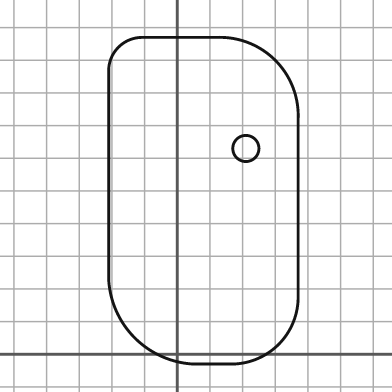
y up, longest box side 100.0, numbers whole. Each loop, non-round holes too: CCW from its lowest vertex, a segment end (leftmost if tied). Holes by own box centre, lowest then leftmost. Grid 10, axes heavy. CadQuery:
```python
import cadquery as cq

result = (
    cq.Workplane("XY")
    .moveTo(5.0, -3.0)
    .lineTo(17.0, -3.0)
    .threePointArc((31.0, 3.0), (37.0, 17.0))
    .lineTo(37.0, 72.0)
    .threePointArc((30.0, 90.0), (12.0, 97.0))
    .lineTo(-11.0, 97.0)
    .threePointArc((-18.0, 94.0), (-21.0, 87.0))
    .lineTo(-21.0, 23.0)
    .threePointArc((-13.0, 5.0), (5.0, -3.0))
    .close()
    .moveTo(21.0, 63.0)
    .circle(4.0)
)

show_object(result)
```